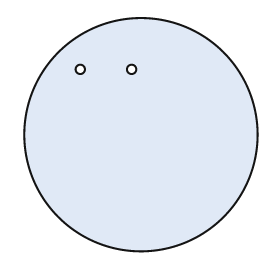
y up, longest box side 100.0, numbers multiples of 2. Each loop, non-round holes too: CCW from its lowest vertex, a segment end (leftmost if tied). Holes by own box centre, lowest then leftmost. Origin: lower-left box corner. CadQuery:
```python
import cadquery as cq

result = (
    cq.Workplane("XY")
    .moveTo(50.0, 50.0)
    .circle(50.0)
    .moveTo(24.0, 78.0)
    .circle(2.0)
    .moveTo(46.0, 78.0)
    .circle(2.0)
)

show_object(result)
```